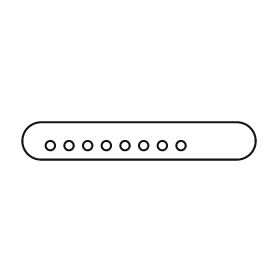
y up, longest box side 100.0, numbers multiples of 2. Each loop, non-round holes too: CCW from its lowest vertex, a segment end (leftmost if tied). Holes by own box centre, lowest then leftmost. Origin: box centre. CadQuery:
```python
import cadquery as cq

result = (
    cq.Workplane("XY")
    .moveTo(-42.0, -8.0)
    .lineTo(42.0, -8.0)
    .threePointArc((50.0, 0.0), (42.0, 8.0))
    .lineTo(-42.0, 8.0)
    .threePointArc((-50.0, 0.0), (-42.0, -8.0))
    .close()
    .moveTo(-38.0, -2.0)
    .circle(2.0)
    .moveTo(-30.0, -2.0)
    .circle(2.0)
    .moveTo(-22.0, -2.0)
    .circle(2.0)
    .moveTo(-14.0, -2.0)
    .circle(2.0)
    .moveTo(-6.0, -2.0)
    .circle(2.0)
    .moveTo(2.0, -2.0)
    .circle(2.0)
    .moveTo(10.0, -2.0)
    .circle(2.0)
    .moveTo(18.0, -2.0)
    .circle(2.0)
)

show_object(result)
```